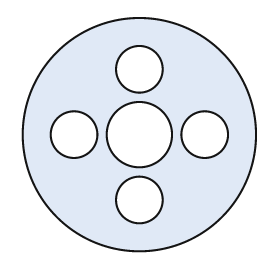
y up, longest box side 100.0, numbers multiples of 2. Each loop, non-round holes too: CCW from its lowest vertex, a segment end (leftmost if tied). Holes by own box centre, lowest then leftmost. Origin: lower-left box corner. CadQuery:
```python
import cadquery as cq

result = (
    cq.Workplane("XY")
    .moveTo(50.0, 50.0)
    .circle(50.0)
    .moveTo(50.0, 22.0)
    .circle(10.0)
    .moveTo(22.0, 50.0)
    .circle(10.0)
    .moveTo(50.0, 50.0)
    .circle(14.0)
    .moveTo(78.0, 50.0)
    .circle(10.0)
    .moveTo(50.0, 78.0)
    .circle(10.0)
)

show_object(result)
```